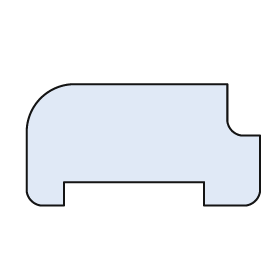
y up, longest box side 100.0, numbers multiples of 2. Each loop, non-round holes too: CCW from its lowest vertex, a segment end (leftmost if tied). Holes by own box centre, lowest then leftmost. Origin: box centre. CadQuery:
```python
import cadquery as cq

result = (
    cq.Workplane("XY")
    .moveTo(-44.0, -26.0)
    .lineTo(-34.0, -26.0)
    .lineTo(-34.0, -16.0)
    .lineTo(26.0, -16.0)
    .lineTo(26.0, -26.0)
    .lineTo(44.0, -26.0)
    .threePointArc((48.0, -24.0), (50.0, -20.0))
    .lineTo(50.0, 4.0)
    .lineTo(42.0, 4.0)
    .threePointArc((38.0, 6.0), (36.0, 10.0))
    .lineTo(36.0, 26.0)
    .lineTo(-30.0, 26.0)
    .threePointArc((-44.0, 20.0), (-50.0, 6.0))
    .lineTo(-50.0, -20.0)
    .threePointArc((-48.0, -24.0), (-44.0, -26.0))
    .close()
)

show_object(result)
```